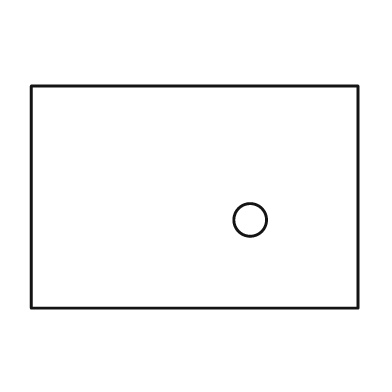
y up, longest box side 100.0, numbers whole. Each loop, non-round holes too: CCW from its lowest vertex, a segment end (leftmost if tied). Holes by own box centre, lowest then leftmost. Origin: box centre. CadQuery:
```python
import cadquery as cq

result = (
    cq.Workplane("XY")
    .moveTo(-50.0, -34.0)
    .lineTo(50.0, -34.0)
    .lineTo(50.0, 34.0)
    .lineTo(-50.0, 34.0)
    .close()
    .moveTo(17.0, -7.0)
    .circle(5.0)
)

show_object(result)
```